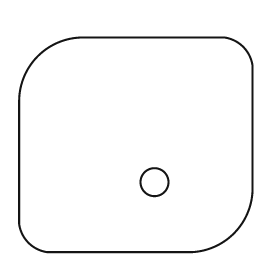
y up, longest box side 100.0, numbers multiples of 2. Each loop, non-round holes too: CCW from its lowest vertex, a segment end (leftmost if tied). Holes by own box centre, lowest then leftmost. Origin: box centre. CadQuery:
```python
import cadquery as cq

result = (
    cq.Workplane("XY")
    .moveTo(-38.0, -46.0)
    .lineTo(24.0, -46.0)
    .threePointArc((42.0, -38.0), (50.0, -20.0))
    .lineTo(50.0, 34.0)
    .threePointArc((46.0, 42.0), (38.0, 46.0))
    .lineTo(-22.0, 46.0)
    .threePointArc((-42.0, 38.0), (-50.0, 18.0))
    .lineTo(-50.0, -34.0)
    .threePointArc((-46.0, -42.0), (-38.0, -46.0))
    .close()
    .moveTo(8.0, -16.0)
    .circle(6.0)
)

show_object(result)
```